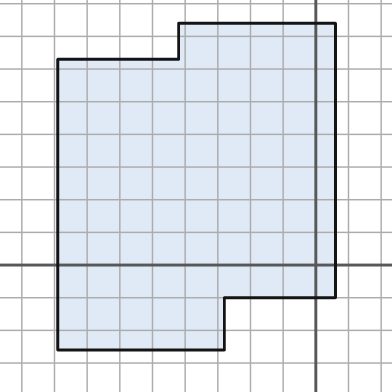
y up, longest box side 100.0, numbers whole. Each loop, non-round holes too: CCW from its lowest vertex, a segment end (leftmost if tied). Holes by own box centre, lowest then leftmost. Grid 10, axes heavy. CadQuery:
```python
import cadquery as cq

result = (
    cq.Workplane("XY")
    .moveTo(-79.0, -26.0)
    .lineTo(-28.0, -26.0)
    .lineTo(-28.0, -10.0)
    .lineTo(6.0, -10.0)
    .lineTo(6.0, 74.0)
    .lineTo(-42.0, 74.0)
    .lineTo(-42.0, 63.0)
    .lineTo(-79.0, 63.0)
    .close()
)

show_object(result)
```